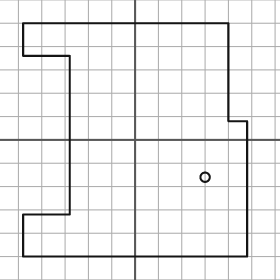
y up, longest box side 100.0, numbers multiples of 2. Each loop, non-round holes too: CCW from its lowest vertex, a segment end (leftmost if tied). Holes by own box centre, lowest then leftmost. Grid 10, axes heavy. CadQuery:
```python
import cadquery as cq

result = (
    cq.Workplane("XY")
    .moveTo(-48.0, -50.0)
    .lineTo(48.0, -50.0)
    .lineTo(48.0, 8.0)
    .lineTo(40.0, 8.0)
    .lineTo(40.0, 50.0)
    .lineTo(-48.0, 50.0)
    .lineTo(-48.0, 36.0)
    .lineTo(-28.0, 36.0)
    .lineTo(-28.0, -32.0)
    .lineTo(-48.0, -32.0)
    .close()
    .moveTo(30.0, -16.0)
    .circle(2.0)
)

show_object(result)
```